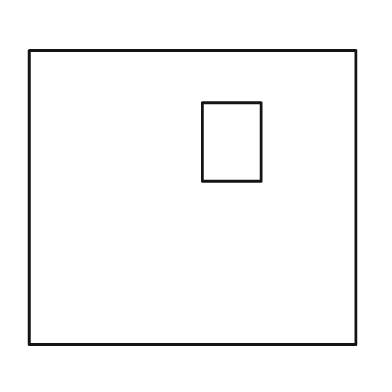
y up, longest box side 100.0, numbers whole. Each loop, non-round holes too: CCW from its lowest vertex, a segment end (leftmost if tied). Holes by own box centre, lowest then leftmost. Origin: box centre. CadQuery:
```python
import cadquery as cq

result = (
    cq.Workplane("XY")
    .moveTo(-50.0, -45.0)
    .lineTo(50.0, -45.0)
    .lineTo(50.0, 45.0)
    .lineTo(-50.0, 45.0)
    .close()
    .moveTo(3.0, 5.0)
    .lineTo(21.0, 5.0)
    .lineTo(21.0, 29.0)
    .lineTo(3.0, 29.0)
    .close()
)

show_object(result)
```